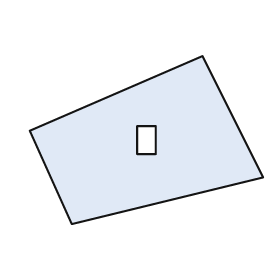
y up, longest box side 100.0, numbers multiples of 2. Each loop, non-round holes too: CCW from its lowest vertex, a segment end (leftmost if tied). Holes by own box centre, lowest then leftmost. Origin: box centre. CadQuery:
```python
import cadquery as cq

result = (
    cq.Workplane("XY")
    .moveTo(-32.0, -36.0)
    .lineTo(50.0, -16.0)
    .lineTo(24.0, 36.0)
    .lineTo(-50.0, 4.0)
    .close()
    .moveTo(-4.0, -6.0)
    .lineTo(4.0, -6.0)
    .lineTo(4.0, 6.0)
    .lineTo(-4.0, 6.0)
    .close()
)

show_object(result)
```